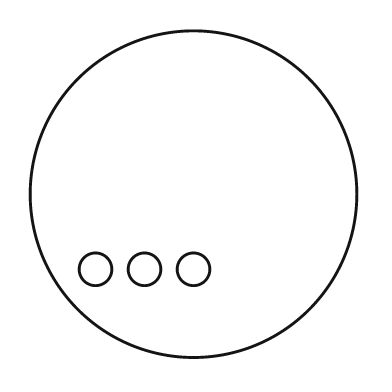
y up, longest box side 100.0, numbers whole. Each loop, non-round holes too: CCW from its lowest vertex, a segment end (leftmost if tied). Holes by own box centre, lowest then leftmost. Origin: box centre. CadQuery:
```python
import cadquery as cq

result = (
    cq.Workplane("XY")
    .moveTo(0.0, 0.0)
    .circle(50.0)
    .moveTo(-30.0, -23.0)
    .circle(5.0)
    .moveTo(-15.0, -23.0)
    .circle(5.0)
    .moveTo(0.0, -23.0)
    .circle(5.0)
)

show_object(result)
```